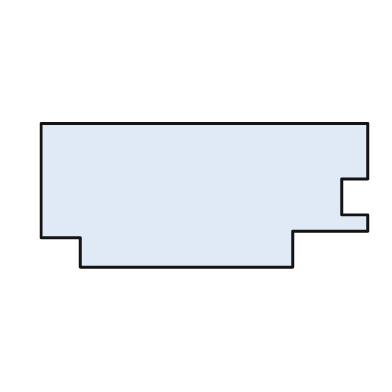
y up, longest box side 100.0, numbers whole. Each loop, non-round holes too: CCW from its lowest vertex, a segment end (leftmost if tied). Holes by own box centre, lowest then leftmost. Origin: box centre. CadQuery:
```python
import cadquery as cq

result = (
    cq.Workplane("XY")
    .moveTo(-38.0, -22.0)
    .lineTo(27.0, -22.0)
    .lineTo(27.0, -11.0)
    .lineTo(50.0, -11.0)
    .lineTo(50.0, -6.0)
    .lineTo(42.0, -6.0)
    .lineTo(42.0, 5.0)
    .lineTo(50.0, 5.0)
    .lineTo(50.0, 22.0)
    .lineTo(-50.0, 22.0)
    .lineTo(-50.0, -13.0)
    .lineTo(-38.0, -13.0)
    .close()
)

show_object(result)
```